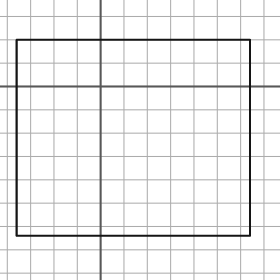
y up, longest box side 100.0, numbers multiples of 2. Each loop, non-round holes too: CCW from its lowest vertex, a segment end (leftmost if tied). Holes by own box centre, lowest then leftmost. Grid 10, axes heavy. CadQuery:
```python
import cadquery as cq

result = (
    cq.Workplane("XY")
    .moveTo(-36.0, -64.0)
    .lineTo(64.0, -64.0)
    .lineTo(64.0, 20.0)
    .lineTo(-36.0, 20.0)
    .close()
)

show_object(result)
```